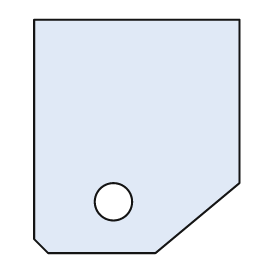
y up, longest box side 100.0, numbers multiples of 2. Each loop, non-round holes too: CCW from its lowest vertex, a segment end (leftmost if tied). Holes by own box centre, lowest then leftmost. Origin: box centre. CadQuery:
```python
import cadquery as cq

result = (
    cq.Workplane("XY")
    .moveTo(-38.0, -50.0)
    .lineTo(8.0, -50.0)
    .lineTo(44.0, -20.0)
    .lineTo(44.0, 50.0)
    .lineTo(-44.0, 50.0)
    .lineTo(-44.0, -44.0)
    .close()
    .moveTo(-10.0, -28.0)
    .circle(8.0)
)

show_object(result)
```